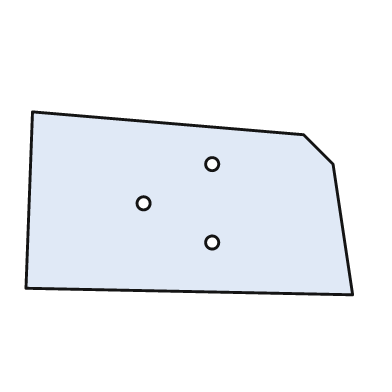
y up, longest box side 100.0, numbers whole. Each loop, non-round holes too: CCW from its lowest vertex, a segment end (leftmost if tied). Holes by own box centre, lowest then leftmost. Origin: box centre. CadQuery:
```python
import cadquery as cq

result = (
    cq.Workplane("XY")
    .moveTo(50.0, -28.0)
    .lineTo(44.0, 12.0)
    .lineTo(35.0, 21.0)
    .lineTo(-48.0, 28.0)
    .lineTo(-50.0, -26.0)
    .close()
    .moveTo(7.0, -12.0)
    .circle(2.0)
    .moveTo(-14.0, 0.0)
    .circle(2.0)
    .moveTo(7.0, 12.0)
    .circle(2.0)
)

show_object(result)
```